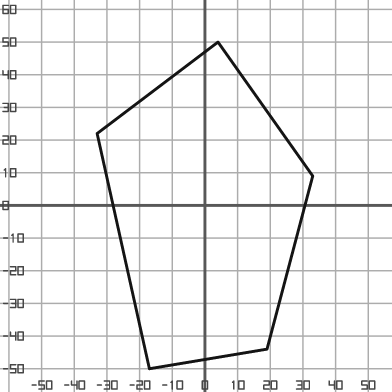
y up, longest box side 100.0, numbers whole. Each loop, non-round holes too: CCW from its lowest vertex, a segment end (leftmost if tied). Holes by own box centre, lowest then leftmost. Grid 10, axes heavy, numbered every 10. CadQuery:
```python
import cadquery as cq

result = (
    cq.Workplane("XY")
    .moveTo(-17.0, -50.0)
    .lineTo(19.0, -44.0)
    .lineTo(33.0, 9.0)
    .lineTo(4.0, 50.0)
    .lineTo(-33.0, 22.0)
    .close()
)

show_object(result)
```